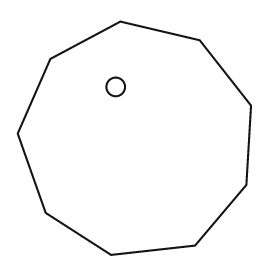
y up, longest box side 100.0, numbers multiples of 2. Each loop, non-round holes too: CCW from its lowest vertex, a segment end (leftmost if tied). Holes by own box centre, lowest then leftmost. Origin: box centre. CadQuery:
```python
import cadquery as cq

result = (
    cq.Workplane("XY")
    .moveTo(-10.0, -50.0)
    .lineTo(26.0, -46.0)
    .lineTo(48.0, -20.0)
    .lineTo(50.0, 14.0)
    .lineTo(28.0, 42.0)
    .lineTo(-6.0, 50.0)
    .lineTo(-36.0, 34.0)
    .lineTo(-50.0, 2.0)
    .lineTo(-38.0, -32.0)
    .close()
    .moveTo(-8.0, 22.0)
    .circle(4.0)
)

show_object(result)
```